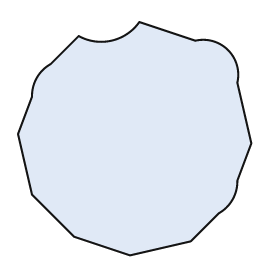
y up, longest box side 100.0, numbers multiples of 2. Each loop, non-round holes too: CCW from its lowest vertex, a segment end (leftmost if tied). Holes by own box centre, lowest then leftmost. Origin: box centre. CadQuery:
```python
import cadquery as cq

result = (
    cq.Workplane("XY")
    .moveTo(-2.0, -50.0)
    .lineTo(24.0, -44.0)
    .lineTo(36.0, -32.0)
    .threePointArc((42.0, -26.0), (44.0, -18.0))
    .lineTo(50.0, -2.0)
    .lineTo(44.0, 24.0)
    .threePointArc((40.0, 38.0), (26.0, 42.0))
    .lineTo(2.0, 50.0)
    .threePointArc((-10.0, 42.0), (-24.0, 44.0))
    .lineTo(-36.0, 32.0)
    .threePointArc((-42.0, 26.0), (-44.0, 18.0))
    .lineTo(-50.0, 2.0)
    .lineTo(-44.0, -24.0)
    .lineTo(-26.0, -42.0)
    .close()
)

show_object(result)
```